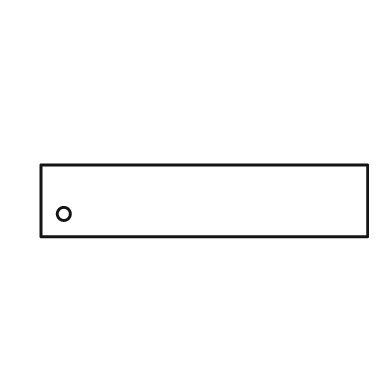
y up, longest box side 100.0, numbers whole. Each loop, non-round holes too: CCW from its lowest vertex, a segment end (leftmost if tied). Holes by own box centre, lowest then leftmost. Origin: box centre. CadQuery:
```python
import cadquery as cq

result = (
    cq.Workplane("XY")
    .moveTo(-50.0, -11.0)
    .lineTo(50.0, -11.0)
    .lineTo(50.0, 11.0)
    .lineTo(-50.0, 11.0)
    .close()
    .moveTo(-43.0, -4.0)
    .circle(2.0)
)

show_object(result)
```